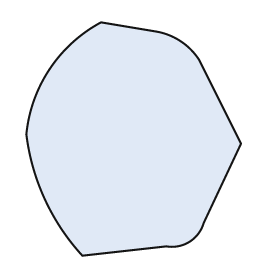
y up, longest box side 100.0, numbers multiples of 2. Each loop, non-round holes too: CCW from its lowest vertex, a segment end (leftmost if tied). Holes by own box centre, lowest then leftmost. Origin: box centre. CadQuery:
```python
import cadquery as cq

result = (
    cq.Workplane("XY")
    .moveTo(-22.0, -50.0)
    .lineTo(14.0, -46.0)
    .threePointArc((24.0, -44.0), (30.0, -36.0))
    .lineTo(46.0, -2.0)
    .lineTo(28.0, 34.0)
    .threePointArc((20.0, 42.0), (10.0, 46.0))
    .lineTo(-14.0, 50.0)
    .threePointArc((-36.0, 30.0), (-46.0, 2.0))
    .threePointArc((-38.0, -26.0), (-22.0, -50.0))
    .close()
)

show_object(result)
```